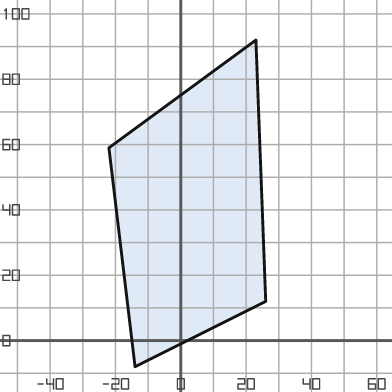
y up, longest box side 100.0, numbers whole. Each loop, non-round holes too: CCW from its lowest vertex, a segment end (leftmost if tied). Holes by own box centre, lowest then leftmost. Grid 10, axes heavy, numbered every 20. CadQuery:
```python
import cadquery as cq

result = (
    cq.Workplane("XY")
    .moveTo(-14.0, -8.0)
    .lineTo(26.0, 12.0)
    .lineTo(23.0, 92.0)
    .lineTo(-22.0, 59.0)
    .close()
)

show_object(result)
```